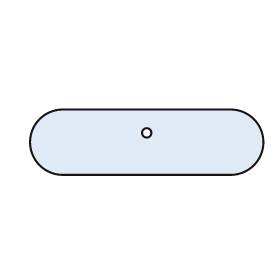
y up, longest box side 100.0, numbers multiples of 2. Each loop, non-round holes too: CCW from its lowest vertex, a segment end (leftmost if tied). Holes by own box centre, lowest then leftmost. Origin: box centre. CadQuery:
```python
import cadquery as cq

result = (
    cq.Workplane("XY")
    .moveTo(-36.0, -14.0)
    .lineTo(36.0, -14.0)
    .threePointArc((50.0, 0.0), (36.0, 14.0))
    .lineTo(-36.0, 14.0)
    .threePointArc((-50.0, 0.0), (-36.0, -14.0))
    .close()
    .moveTo(0.0, 4.0)
    .circle(2.0)
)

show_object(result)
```